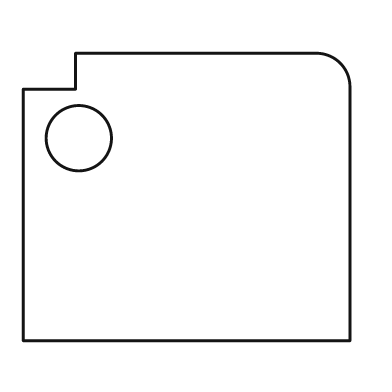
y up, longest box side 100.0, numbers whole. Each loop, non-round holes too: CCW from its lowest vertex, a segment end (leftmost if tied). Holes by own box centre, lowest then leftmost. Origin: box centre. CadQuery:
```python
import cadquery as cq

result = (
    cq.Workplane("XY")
    .moveTo(-50.0, -44.0)
    .lineTo(50.0, -44.0)
    .lineTo(50.0, 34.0)
    .threePointArc((47.0, 41.0), (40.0, 44.0))
    .lineTo(-34.0, 44.0)
    .lineTo(-34.0, 33.0)
    .lineTo(-50.0, 33.0)
    .close()
    .moveTo(-33.0, 18.0)
    .circle(10.0)
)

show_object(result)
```